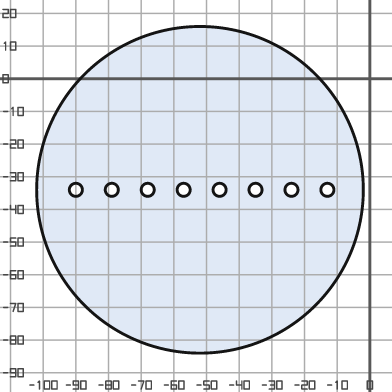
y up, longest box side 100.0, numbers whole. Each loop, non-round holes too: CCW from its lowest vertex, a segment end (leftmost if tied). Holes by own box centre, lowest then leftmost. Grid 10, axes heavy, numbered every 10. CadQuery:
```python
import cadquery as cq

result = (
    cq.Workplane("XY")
    .moveTo(-52.0, -34.0)
    .circle(50.0)
    .moveTo(-90.0, -34.0)
    .circle(2.0)
    .moveTo(-79.0, -34.0)
    .circle(2.0)
    .moveTo(-68.0, -34.0)
    .circle(2.0)
    .moveTo(-57.0, -34.0)
    .circle(2.0)
    .moveTo(-46.0, -34.0)
    .circle(2.0)
    .moveTo(-35.0, -34.0)
    .circle(2.0)
    .moveTo(-24.0, -34.0)
    .circle(2.0)
    .moveTo(-13.0, -34.0)
    .circle(2.0)
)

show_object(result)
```